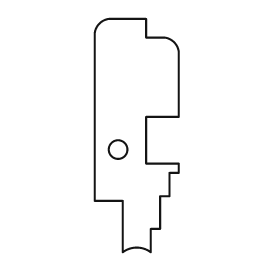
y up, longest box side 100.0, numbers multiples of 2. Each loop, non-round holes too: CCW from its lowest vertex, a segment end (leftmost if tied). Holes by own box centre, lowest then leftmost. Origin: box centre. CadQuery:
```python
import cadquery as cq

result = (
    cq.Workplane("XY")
    .moveTo(-6.0, -50.0)
    .threePointArc((0.0, -48.0), (6.0, -50.0))
    .lineTo(6.0, -40.0)
    .lineTo(10.0, -40.0)
    .lineTo(10.0, -26.0)
    .lineTo(14.0, -26.0)
    .lineTo(14.0, -16.0)
    .lineTo(18.0, -16.0)
    .lineTo(18.0, -12.0)
    .lineTo(4.0, -12.0)
    .lineTo(4.0, 8.0)
    .lineTo(18.0, 8.0)
    .lineTo(18.0, 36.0)
    .threePointArc((16.0, 40.0), (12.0, 42.0))
    .lineTo(4.0, 42.0)
    .lineTo(4.0, 50.0)
    .lineTo(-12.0, 50.0)
    .threePointArc((-16.0, 48.0), (-18.0, 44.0))
    .lineTo(-18.0, -28.0)
    .lineTo(-6.0, -28.0)
    .close()
    .moveTo(-8.0, -6.0)
    .circle(4.0)
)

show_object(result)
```